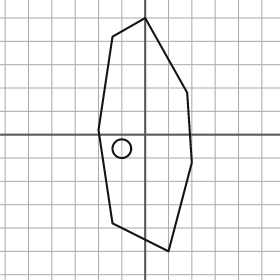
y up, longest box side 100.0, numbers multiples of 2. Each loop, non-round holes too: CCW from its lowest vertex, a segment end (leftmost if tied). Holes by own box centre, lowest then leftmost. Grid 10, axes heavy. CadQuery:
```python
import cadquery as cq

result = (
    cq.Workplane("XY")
    .moveTo(10.0, -50.0)
    .lineTo(20.0, -12.0)
    .lineTo(18.0, 18.0)
    .lineTo(0.0, 50.0)
    .lineTo(-14.0, 42.0)
    .lineTo(-20.0, 2.0)
    .lineTo(-14.0, -38.0)
    .close()
    .moveTo(-10.0, -6.0)
    .circle(4.0)
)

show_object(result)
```